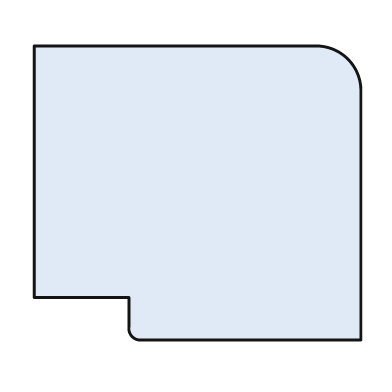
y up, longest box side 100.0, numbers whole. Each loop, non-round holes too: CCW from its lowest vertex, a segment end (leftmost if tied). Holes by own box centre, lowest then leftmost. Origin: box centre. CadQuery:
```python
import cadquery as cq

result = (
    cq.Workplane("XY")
    .moveTo(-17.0, -45.0)
    .lineTo(50.0, -45.0)
    .lineTo(50.0, 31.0)
    .threePointArc((46.0, 41.0), (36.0, 45.0))
    .lineTo(-50.0, 45.0)
    .lineTo(-50.0, -32.0)
    .lineTo(-21.0, -32.0)
    .lineTo(-21.0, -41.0)
    .threePointArc((-20.0, -44.0), (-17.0, -45.0))
    .close()
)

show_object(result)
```